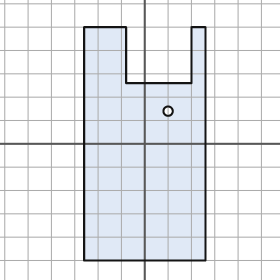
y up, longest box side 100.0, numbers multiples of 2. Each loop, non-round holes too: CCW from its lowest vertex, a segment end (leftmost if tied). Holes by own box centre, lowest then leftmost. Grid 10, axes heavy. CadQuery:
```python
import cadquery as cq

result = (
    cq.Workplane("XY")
    .moveTo(-26.0, -50.0)
    .lineTo(26.0, -50.0)
    .lineTo(26.0, 50.0)
    .lineTo(20.0, 50.0)
    .lineTo(20.0, 26.0)
    .lineTo(-8.0, 26.0)
    .lineTo(-8.0, 50.0)
    .lineTo(-26.0, 50.0)
    .close()
    .moveTo(10.0, 14.0)
    .circle(2.0)
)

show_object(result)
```